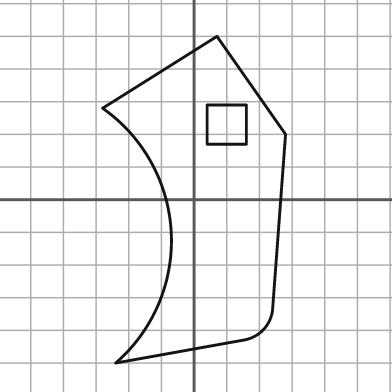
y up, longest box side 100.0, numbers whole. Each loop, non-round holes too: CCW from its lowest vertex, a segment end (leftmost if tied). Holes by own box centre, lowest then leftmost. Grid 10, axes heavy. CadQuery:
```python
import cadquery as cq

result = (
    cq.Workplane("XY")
    .moveTo(-24.0, -50.0)
    .lineTo(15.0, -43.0)
    .threePointArc((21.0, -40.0), (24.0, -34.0))
    .lineTo(28.0, 20.0)
    .lineTo(7.0, 50.0)
    .lineTo(-28.0, 28.0)
    .threePointArc((-7.0, -10.0), (-24.0, -50.0))
    .close()
    .moveTo(4.0, 17.0)
    .lineTo(16.0, 17.0)
    .lineTo(16.0, 29.0)
    .lineTo(4.0, 29.0)
    .close()
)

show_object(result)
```